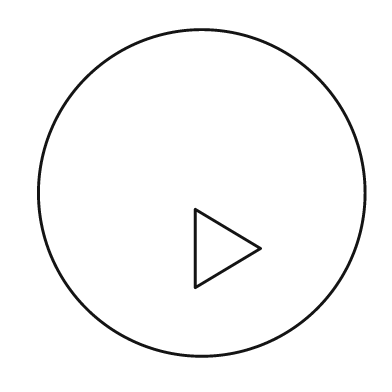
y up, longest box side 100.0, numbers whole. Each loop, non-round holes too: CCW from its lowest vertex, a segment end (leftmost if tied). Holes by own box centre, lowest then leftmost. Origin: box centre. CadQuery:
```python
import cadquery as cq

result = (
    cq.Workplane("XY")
    .moveTo(0.0, 0.0)
    .circle(50.0)
    .moveTo(-2.0, -29.0)
    .lineTo(18.0, -17.0)
    .lineTo(-2.0, -5.0)
    .close()
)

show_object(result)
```